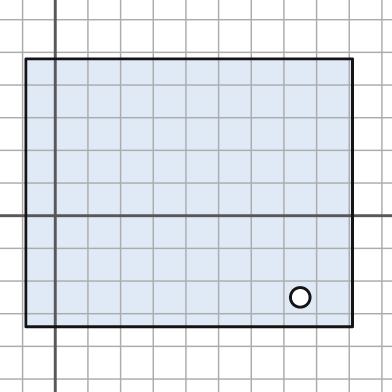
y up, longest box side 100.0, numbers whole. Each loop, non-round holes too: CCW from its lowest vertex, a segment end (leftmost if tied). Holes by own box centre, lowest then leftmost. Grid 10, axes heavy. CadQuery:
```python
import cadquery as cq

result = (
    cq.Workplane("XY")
    .moveTo(-9.0, -34.0)
    .lineTo(91.0, -34.0)
    .lineTo(91.0, 48.0)
    .lineTo(-9.0, 48.0)
    .close()
    .moveTo(75.0, -25.0)
    .circle(3.0)
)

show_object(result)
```